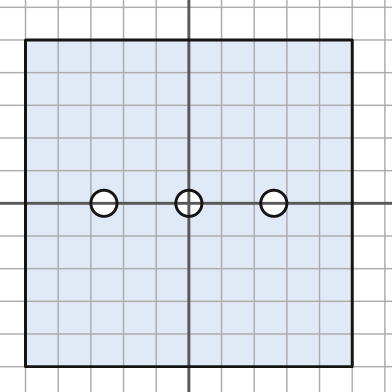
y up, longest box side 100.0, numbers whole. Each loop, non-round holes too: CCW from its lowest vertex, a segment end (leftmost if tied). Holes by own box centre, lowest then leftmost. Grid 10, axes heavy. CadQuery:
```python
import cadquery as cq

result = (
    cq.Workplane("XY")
    .moveTo(-50.0, -50.0)
    .lineTo(50.0, -50.0)
    .lineTo(50.0, 50.0)
    .lineTo(-50.0, 50.0)
    .close()
    .moveTo(-26.0, 0.0)
    .circle(4.0)
    .moveTo(0.0, 0.0)
    .circle(4.0)
    .moveTo(26.0, 0.0)
    .circle(4.0)
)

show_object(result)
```